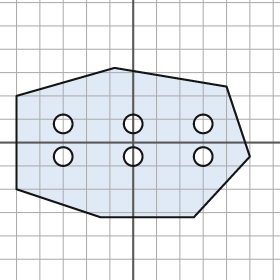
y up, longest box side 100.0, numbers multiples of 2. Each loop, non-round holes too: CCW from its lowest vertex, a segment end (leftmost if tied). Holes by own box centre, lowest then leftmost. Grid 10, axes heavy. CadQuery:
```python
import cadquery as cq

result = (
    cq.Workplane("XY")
    .moveTo(-14.0, -32.0)
    .lineTo(26.0, -32.0)
    .lineTo(50.0, -6.0)
    .lineTo(40.0, 24.0)
    .lineTo(-8.0, 32.0)
    .lineTo(-50.0, 20.0)
    .lineTo(-50.0, -20.0)
    .close()
    .moveTo(-30.0, -6.0)
    .circle(4.0)
    .moveTo(0.0, -6.0)
    .circle(4.0)
    .moveTo(30.0, -6.0)
    .circle(4.0)
    .moveTo(-30.0, 8.0)
    .circle(4.0)
    .moveTo(0.0, 8.0)
    .circle(4.0)
    .moveTo(30.0, 8.0)
    .circle(4.0)
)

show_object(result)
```